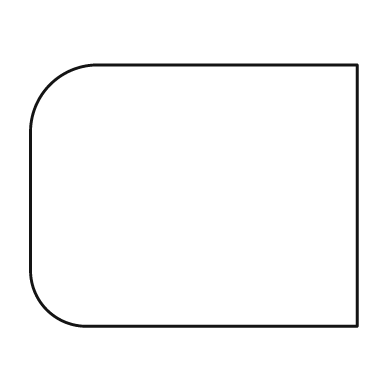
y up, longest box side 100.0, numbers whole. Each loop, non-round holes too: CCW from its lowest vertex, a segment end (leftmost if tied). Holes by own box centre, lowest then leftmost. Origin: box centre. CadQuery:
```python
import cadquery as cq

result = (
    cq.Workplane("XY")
    .moveTo(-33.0, -40.0)
    .lineTo(50.0, -40.0)
    .lineTo(50.0, 40.0)
    .lineTo(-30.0, 40.0)
    .threePointArc((-44.0, 34.0), (-50.0, 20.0))
    .lineTo(-50.0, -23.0)
    .threePointArc((-45.0, -35.0), (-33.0, -40.0))
    .close()
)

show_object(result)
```